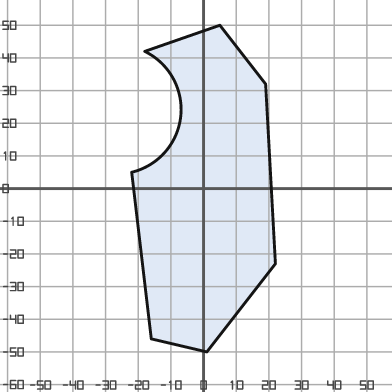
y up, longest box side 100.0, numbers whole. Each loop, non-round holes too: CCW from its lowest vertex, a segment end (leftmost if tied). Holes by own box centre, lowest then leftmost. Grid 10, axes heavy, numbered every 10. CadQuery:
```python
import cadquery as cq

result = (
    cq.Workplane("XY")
    .moveTo(1.0, -50.0)
    .lineTo(22.0, -23.0)
    .lineTo(19.0, 32.0)
    .lineTo(5.0, 50.0)
    .lineTo(-18.0, 42.0)
    .threePointArc((-7.0, 22.0), (-22.0, 5.0))
    .lineTo(-16.0, -46.0)
    .close()
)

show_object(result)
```